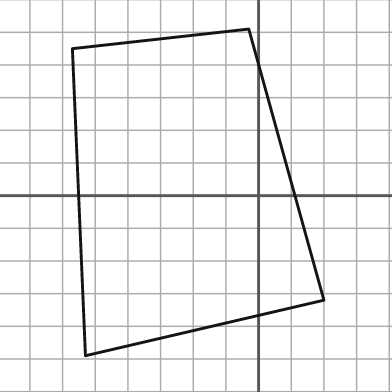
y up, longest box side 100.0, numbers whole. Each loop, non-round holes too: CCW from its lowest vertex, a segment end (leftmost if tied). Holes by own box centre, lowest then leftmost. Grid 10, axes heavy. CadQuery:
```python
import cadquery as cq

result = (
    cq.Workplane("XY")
    .moveTo(-53.0, -49.0)
    .lineTo(20.0, -32.0)
    .lineTo(-3.0, 51.0)
    .lineTo(-57.0, 45.0)
    .close()
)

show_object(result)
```